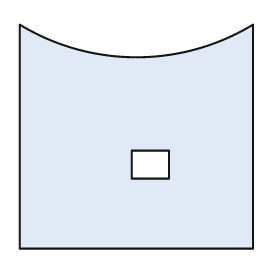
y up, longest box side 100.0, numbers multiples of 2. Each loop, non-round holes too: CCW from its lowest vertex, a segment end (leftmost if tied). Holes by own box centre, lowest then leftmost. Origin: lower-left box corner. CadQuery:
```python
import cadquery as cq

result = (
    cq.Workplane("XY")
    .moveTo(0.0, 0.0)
    .lineTo(100.0, 0.0)
    .lineTo(100.0, 96.0)
    .threePointArc((50.0, 82.0), (0.0, 96.0))
    .close()
    .moveTo(48.0, 30.0)
    .lineTo(64.0, 30.0)
    .lineTo(64.0, 42.0)
    .lineTo(48.0, 42.0)
    .close()
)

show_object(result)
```